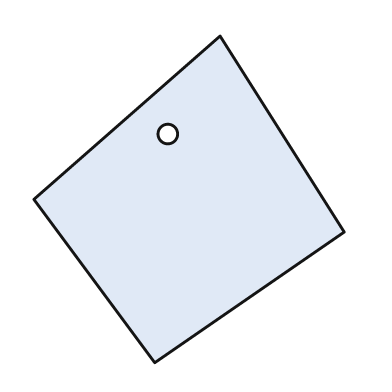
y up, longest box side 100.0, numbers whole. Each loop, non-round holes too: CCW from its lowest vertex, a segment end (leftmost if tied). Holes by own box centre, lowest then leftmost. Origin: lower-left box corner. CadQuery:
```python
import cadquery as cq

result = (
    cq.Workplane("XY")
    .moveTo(37.0, 0.0)
    .lineTo(95.0, 40.0)
    .lineTo(57.0, 100.0)
    .lineTo(0.0, 50.0)
    .close()
    .moveTo(41.0, 70.0)
    .circle(3.0)
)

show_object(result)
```